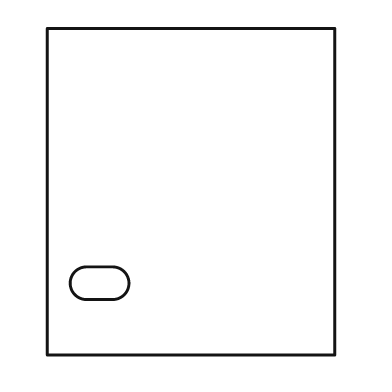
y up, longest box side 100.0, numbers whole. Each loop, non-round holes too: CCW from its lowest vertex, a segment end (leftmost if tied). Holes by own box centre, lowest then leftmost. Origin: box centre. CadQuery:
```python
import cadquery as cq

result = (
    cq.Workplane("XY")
    .moveTo(-44.0, -50.0)
    .lineTo(44.0, -50.0)
    .lineTo(44.0, 50.0)
    .lineTo(-44.0, 50.0)
    .close()
    .moveTo(-32.0, -33.0)
    .lineTo(-24.0, -33.0)
    .threePointArc((-19.0, -28.0), (-24.0, -23.0))
    .lineTo(-32.0, -23.0)
    .threePointArc((-37.0, -28.0), (-32.0, -33.0))
    .close()
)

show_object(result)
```